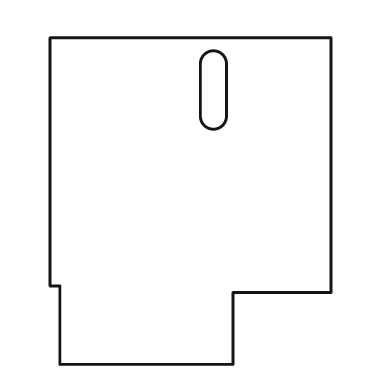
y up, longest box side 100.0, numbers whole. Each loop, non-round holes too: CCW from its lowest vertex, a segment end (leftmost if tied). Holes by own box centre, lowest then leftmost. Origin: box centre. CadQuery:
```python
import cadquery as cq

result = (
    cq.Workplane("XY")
    .moveTo(-40.0, -50.0)
    .lineTo(13.0, -50.0)
    .lineTo(13.0, -28.0)
    .lineTo(43.0, -28.0)
    .lineTo(43.0, 50.0)
    .lineTo(-43.0, 50.0)
    .lineTo(-43.0, -26.0)
    .lineTo(-40.0, -26.0)
    .close()
    .moveTo(3.0, 26.0)
    .threePointArc((7.0, 22.0), (11.0, 26.0))
    .lineTo(11.0, 42.0)
    .threePointArc((7.0, 46.0), (3.0, 42.0))
    .close()
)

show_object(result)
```